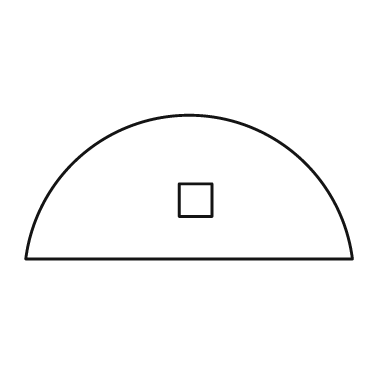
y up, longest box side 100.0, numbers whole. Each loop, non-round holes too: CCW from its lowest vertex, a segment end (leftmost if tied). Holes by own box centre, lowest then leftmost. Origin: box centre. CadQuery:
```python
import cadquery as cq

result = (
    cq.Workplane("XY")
    .moveTo(-50.0, -22.0)
    .lineTo(50.0, -22.0)
    .threePointArc((0.0, 22.0), (-50.0, -22.0))
    .close()
    .moveTo(-3.0, -9.0)
    .lineTo(7.0, -9.0)
    .lineTo(7.0, 1.0)
    .lineTo(-3.0, 1.0)
    .close()
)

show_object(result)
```